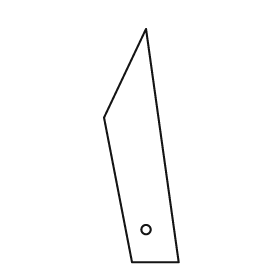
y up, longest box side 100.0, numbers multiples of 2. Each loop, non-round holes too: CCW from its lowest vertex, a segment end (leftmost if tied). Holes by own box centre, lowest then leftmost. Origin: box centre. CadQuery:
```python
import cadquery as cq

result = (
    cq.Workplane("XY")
    .moveTo(-4.0, -50.0)
    .lineTo(16.0, -50.0)
    .lineTo(2.0, 50.0)
    .lineTo(-16.0, 12.0)
    .close()
    .moveTo(2.0, -36.0)
    .circle(2.0)
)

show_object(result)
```